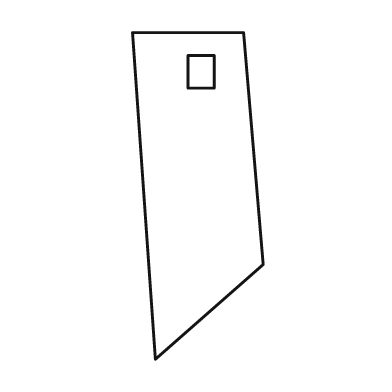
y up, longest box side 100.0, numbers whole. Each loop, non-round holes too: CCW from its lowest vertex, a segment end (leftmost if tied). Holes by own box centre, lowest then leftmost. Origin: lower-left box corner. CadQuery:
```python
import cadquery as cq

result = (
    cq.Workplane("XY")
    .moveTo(7.0, 0.0)
    .lineTo(40.0, 29.0)
    .lineTo(34.0, 100.0)
    .lineTo(0.0, 100.0)
    .close()
    .moveTo(17.0, 83.0)
    .lineTo(25.0, 83.0)
    .lineTo(25.0, 93.0)
    .lineTo(17.0, 93.0)
    .close()
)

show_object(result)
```